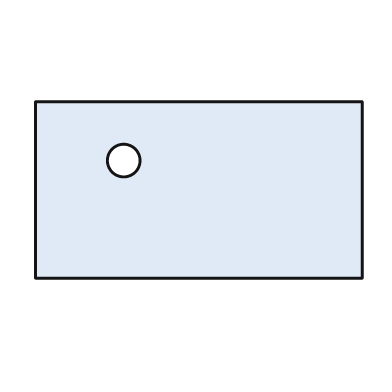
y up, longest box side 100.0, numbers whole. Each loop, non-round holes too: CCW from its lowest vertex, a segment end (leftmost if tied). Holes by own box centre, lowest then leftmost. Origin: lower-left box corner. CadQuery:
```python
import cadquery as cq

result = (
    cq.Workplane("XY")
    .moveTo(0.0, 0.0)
    .lineTo(100.0, 0.0)
    .lineTo(100.0, 54.0)
    .lineTo(0.0, 54.0)
    .close()
    .moveTo(27.0, 36.0)
    .circle(5.0)
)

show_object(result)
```